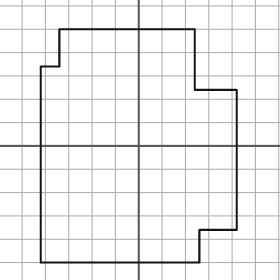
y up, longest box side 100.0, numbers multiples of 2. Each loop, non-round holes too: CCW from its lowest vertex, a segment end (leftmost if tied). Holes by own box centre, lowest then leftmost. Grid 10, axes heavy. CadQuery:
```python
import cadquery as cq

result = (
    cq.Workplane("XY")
    .moveTo(-42.0, -50.0)
    .lineTo(26.0, -50.0)
    .lineTo(26.0, -36.0)
    .lineTo(42.0, -36.0)
    .lineTo(42.0, 24.0)
    .lineTo(24.0, 24.0)
    .lineTo(24.0, 50.0)
    .lineTo(-34.0, 50.0)
    .lineTo(-34.0, 34.0)
    .lineTo(-42.0, 34.0)
    .close()
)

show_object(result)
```